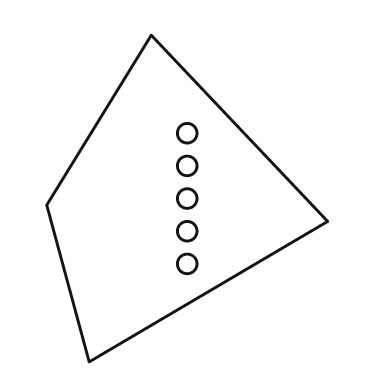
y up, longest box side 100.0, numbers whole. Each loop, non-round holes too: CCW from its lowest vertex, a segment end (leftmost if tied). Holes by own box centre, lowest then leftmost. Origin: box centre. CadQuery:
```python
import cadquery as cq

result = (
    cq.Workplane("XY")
    .moveTo(-30.0, -50.0)
    .lineTo(43.0, -7.0)
    .lineTo(-11.0, 50.0)
    .lineTo(-43.0, -2.0)
    .close()
    .moveTo(0.0, -20.0)
    .circle(3.0)
    .moveTo(0.0, -10.0)
    .circle(3.0)
    .moveTo(0.0, 0.0)
    .circle(3.0)
    .moveTo(0.0, 10.0)
    .circle(3.0)
    .moveTo(0.0, 20.0)
    .circle(3.0)
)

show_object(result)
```